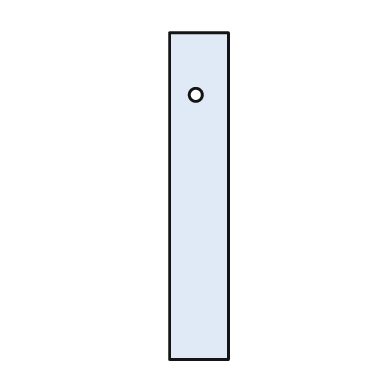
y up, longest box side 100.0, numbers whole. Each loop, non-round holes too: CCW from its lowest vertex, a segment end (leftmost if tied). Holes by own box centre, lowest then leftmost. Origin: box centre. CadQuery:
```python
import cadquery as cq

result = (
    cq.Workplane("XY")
    .moveTo(-9.0, -50.0)
    .lineTo(9.0, -50.0)
    .lineTo(9.0, 50.0)
    .lineTo(-9.0, 50.0)
    .close()
    .moveTo(-1.0, 31.0)
    .circle(2.0)
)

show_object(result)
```